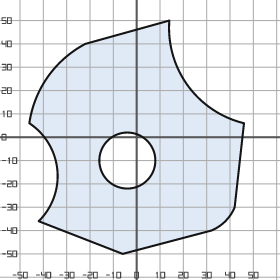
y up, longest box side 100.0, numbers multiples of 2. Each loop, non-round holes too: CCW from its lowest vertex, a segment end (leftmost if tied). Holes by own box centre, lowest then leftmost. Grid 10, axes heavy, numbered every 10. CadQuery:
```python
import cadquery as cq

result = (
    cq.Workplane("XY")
    .moveTo(-6.0, -50.0)
    .lineTo(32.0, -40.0)
    .threePointArc((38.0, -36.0), (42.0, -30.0))
    .lineTo(46.0, 6.0)
    .threePointArc((22.0, 22.0), (14.0, 50.0))
    .lineTo(-22.0, 40.0)
    .threePointArc((-38.0, 26.0), (-46.0, 6.0))
    .threePointArc((-34.0, -14.0), (-42.0, -36.0))
    .close()
    .moveTo(-4.0, -10.0)
    .circle(12.0)
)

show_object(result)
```